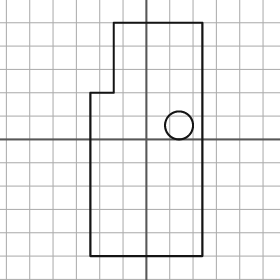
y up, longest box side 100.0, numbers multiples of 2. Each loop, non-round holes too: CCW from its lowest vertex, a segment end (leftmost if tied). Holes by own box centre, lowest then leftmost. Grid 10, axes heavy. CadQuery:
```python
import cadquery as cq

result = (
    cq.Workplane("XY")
    .moveTo(-24.0, -50.0)
    .lineTo(24.0, -50.0)
    .lineTo(24.0, 50.0)
    .lineTo(-14.0, 50.0)
    .lineTo(-14.0, 20.0)
    .lineTo(-24.0, 20.0)
    .close()
    .moveTo(14.0, 6.0)
    .circle(6.0)
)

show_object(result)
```